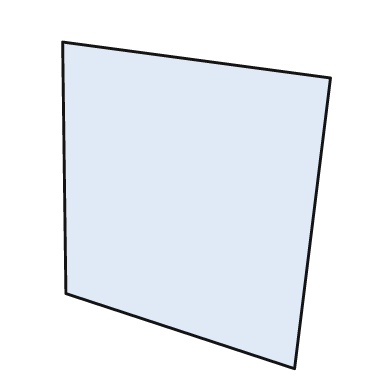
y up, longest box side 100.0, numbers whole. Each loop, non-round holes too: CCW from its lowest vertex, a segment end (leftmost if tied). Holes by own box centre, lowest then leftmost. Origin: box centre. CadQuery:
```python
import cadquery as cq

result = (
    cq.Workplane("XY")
    .moveTo(30.0, -50.0)
    .lineTo(41.0, 39.0)
    .lineTo(-41.0, 50.0)
    .lineTo(-40.0, -27.0)
    .close()
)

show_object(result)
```